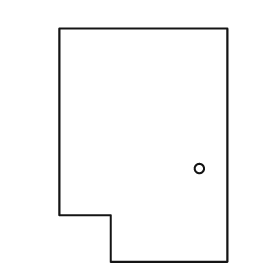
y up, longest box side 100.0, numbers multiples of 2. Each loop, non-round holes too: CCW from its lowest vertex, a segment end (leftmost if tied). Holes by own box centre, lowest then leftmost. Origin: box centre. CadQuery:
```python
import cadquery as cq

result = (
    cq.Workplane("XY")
    .moveTo(-14.0, -50.0)
    .lineTo(36.0, -50.0)
    .lineTo(36.0, 50.0)
    .lineTo(-36.0, 50.0)
    .lineTo(-36.0, -30.0)
    .lineTo(-14.0, -30.0)
    .close()
    .moveTo(24.0, -10.0)
    .circle(2.0)
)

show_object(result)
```